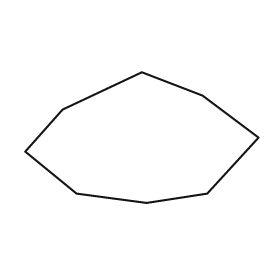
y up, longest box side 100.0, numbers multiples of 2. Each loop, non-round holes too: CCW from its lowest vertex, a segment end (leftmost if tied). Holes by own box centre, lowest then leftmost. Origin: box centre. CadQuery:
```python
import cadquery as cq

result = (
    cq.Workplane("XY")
    .moveTo(2.0, -28.0)
    .lineTo(28.0, -24.0)
    .lineTo(50.0, 0.0)
    .lineTo(26.0, 18.0)
    .lineTo(0.0, 28.0)
    .lineTo(-34.0, 12.0)
    .lineTo(-50.0, -6.0)
    .lineTo(-28.0, -24.0)
    .close()
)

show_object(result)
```